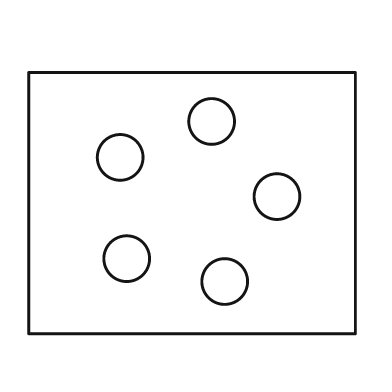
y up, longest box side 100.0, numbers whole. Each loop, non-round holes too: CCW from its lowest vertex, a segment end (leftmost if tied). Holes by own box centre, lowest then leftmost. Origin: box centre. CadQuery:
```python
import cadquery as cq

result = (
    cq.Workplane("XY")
    .moveTo(-50.0, -40.0)
    .lineTo(50.0, -40.0)
    .lineTo(50.0, 40.0)
    .lineTo(-50.0, 40.0)
    .close()
    .moveTo(10.0, -24.0)
    .circle(7.0)
    .moveTo(-20.0, -17.0)
    .circle(7.0)
    .moveTo(26.0, 2.0)
    .circle(7.0)
    .moveTo(-22.0, 14.0)
    .circle(7.0)
    .moveTo(6.0, 25.0)
    .circle(7.0)
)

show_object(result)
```